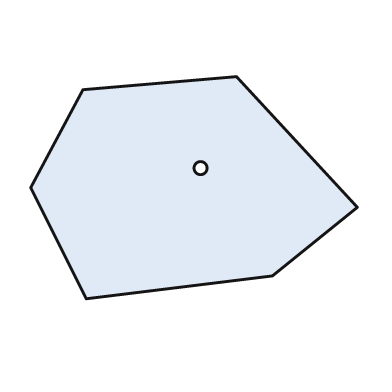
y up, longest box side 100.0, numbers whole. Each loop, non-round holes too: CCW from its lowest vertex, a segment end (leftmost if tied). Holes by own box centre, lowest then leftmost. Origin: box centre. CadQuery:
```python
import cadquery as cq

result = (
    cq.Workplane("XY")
    .moveTo(-33.0, -34.0)
    .lineTo(24.0, -27.0)
    .lineTo(50.0, -6.0)
    .lineTo(13.0, 34.0)
    .lineTo(-34.0, 30.0)
    .lineTo(-50.0, 0.0)
    .close()
    .moveTo(2.0, 6.0)
    .circle(2.0)
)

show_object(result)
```